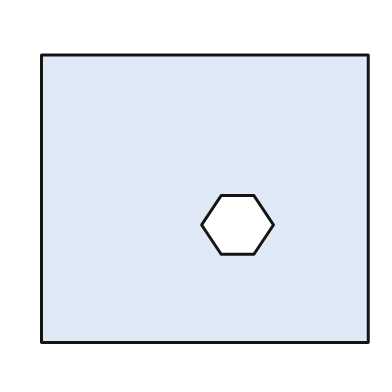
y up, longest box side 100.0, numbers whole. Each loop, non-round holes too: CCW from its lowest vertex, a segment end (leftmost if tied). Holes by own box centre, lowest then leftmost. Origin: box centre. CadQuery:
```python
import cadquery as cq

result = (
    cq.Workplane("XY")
    .moveTo(-50.0, -44.0)
    .lineTo(50.0, -44.0)
    .lineTo(50.0, 44.0)
    .lineTo(-50.0, 44.0)
    .close()
    .moveTo(5.0, -17.0)
    .lineTo(15.0, -17.0)
    .lineTo(21.0, -8.0)
    .lineTo(15.0, 1.0)
    .lineTo(5.0, 1.0)
    .lineTo(-1.0, -8.0)
    .close()
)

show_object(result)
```